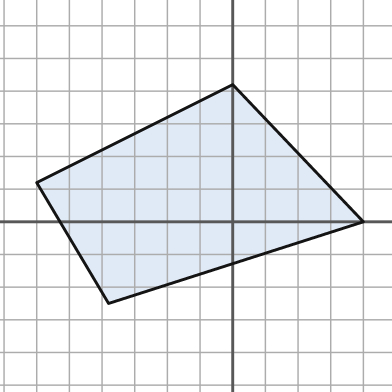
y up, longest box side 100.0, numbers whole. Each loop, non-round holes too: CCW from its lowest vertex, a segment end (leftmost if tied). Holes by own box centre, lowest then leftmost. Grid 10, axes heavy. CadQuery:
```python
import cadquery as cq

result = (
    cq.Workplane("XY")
    .moveTo(-38.0, -25.0)
    .lineTo(40.0, 0.0)
    .lineTo(0.0, 42.0)
    .lineTo(-60.0, 12.0)
    .close()
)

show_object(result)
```